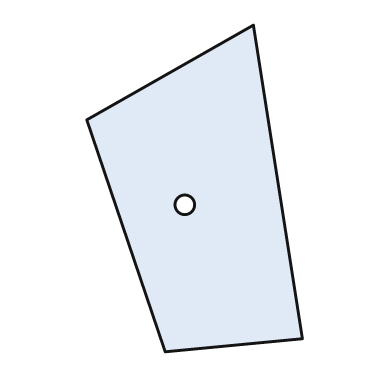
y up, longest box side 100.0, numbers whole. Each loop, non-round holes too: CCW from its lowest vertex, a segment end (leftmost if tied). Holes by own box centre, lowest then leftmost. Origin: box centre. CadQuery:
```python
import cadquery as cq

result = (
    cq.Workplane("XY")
    .moveTo(-9.0, -50.0)
    .lineTo(33.0, -46.0)
    .lineTo(18.0, 50.0)
    .lineTo(-33.0, 21.0)
    .close()
    .moveTo(-3.0, -5.0)
    .circle(3.0)
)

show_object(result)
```